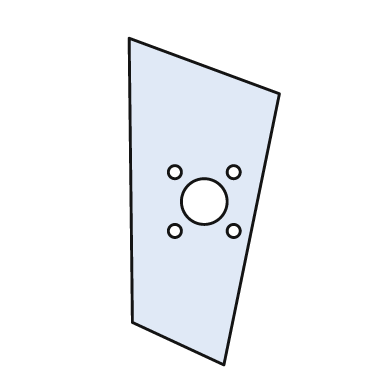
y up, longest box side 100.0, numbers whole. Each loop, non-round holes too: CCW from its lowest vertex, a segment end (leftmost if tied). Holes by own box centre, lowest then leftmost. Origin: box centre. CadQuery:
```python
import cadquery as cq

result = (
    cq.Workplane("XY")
    .moveTo(6.0, -50.0)
    .lineTo(23.0, 33.0)
    .lineTo(-23.0, 50.0)
    .lineTo(-22.0, -37.0)
    .close()
    .moveTo(-9.0, -9.0)
    .circle(2.0)
    .moveTo(9.0, -9.0)
    .circle(2.0)
    .moveTo(0.0, 0.0)
    .circle(7.0)
    .moveTo(-9.0, 9.0)
    .circle(2.0)
    .moveTo(9.0, 9.0)
    .circle(2.0)
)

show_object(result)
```